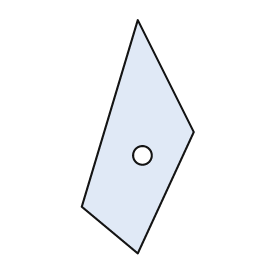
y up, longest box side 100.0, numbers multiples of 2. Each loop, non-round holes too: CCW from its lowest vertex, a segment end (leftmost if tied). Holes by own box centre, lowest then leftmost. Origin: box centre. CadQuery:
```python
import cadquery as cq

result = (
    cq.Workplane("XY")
    .moveTo(0.0, -50.0)
    .lineTo(24.0, 2.0)
    .lineTo(0.0, 50.0)
    .lineTo(-24.0, -30.0)
    .close()
    .moveTo(2.0, -8.0)
    .circle(4.0)
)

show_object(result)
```